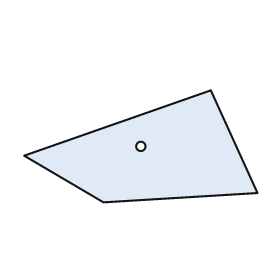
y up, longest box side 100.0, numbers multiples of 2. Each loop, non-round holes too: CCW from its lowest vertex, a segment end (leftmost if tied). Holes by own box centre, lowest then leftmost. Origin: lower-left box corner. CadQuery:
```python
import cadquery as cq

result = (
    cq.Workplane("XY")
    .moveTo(34.0, 0.0)
    .lineTo(100.0, 4.0)
    .lineTo(80.0, 48.0)
    .lineTo(0.0, 20.0)
    .close()
    .moveTo(50.0, 24.0)
    .circle(2.0)
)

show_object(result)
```